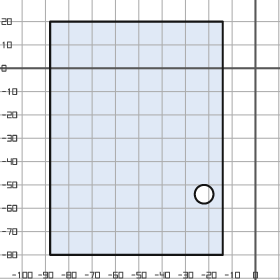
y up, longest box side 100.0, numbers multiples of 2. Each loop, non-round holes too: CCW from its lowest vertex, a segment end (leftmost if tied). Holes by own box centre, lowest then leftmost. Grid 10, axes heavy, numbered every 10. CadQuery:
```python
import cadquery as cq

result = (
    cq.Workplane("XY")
    .moveTo(-88.0, -80.0)
    .lineTo(-14.0, -80.0)
    .lineTo(-14.0, 20.0)
    .lineTo(-88.0, 20.0)
    .close()
    .moveTo(-22.0, -54.0)
    .circle(4.0)
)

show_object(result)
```